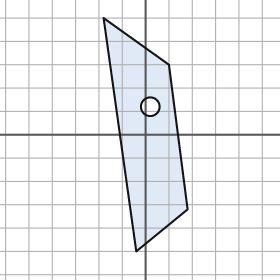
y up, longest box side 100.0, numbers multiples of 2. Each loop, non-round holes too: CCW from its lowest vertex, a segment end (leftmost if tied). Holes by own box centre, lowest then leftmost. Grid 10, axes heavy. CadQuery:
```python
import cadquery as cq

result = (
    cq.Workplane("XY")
    .moveTo(-4.0, -50.0)
    .lineTo(18.0, -32.0)
    .lineTo(10.0, 30.0)
    .lineTo(-18.0, 50.0)
    .close()
    .moveTo(2.0, 12.0)
    .circle(4.0)
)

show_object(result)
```